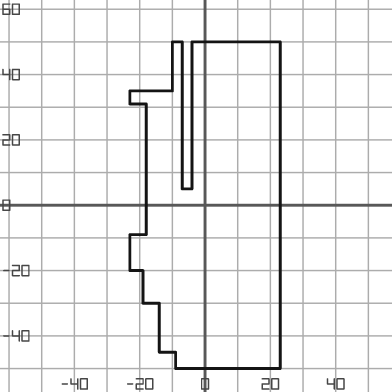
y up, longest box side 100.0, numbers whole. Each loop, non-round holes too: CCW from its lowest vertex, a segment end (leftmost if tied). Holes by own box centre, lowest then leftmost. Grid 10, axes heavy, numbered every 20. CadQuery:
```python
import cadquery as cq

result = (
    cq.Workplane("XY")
    .moveTo(-9.0, -50.0)
    .lineTo(23.0, -50.0)
    .lineTo(23.0, 50.0)
    .lineTo(-4.0, 50.0)
    .lineTo(-4.0, 5.0)
    .lineTo(-7.0, 5.0)
    .lineTo(-7.0, 50.0)
    .lineTo(-10.0, 50.0)
    .lineTo(-10.0, 35.0)
    .lineTo(-23.0, 35.0)
    .lineTo(-23.0, 31.0)
    .lineTo(-18.0, 31.0)
    .lineTo(-18.0, -9.0)
    .lineTo(-23.0, -9.0)
    .lineTo(-23.0, -20.0)
    .lineTo(-19.0, -20.0)
    .lineTo(-19.0, -30.0)
    .lineTo(-14.0, -30.0)
    .lineTo(-14.0, -45.0)
    .lineTo(-9.0, -45.0)
    .close()
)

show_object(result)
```